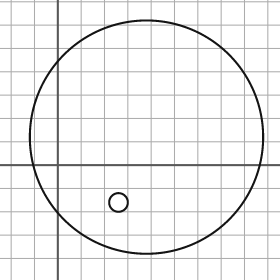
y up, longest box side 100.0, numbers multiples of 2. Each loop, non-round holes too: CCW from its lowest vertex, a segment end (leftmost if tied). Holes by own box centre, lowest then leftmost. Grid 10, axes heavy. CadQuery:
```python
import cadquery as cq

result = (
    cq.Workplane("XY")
    .moveTo(38.0, 12.0)
    .circle(50.0)
    .moveTo(26.0, -16.0)
    .circle(4.0)
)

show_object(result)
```